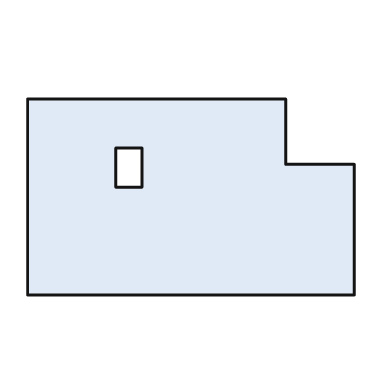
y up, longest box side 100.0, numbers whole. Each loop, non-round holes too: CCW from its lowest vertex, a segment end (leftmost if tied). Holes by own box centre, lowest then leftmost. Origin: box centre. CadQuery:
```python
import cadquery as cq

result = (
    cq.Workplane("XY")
    .moveTo(-50.0, -30.0)
    .lineTo(50.0, -30.0)
    .lineTo(50.0, 10.0)
    .lineTo(29.0, 10.0)
    .lineTo(29.0, 30.0)
    .lineTo(-50.0, 30.0)
    .close()
    .moveTo(-23.0, 3.0)
    .lineTo(-15.0, 3.0)
    .lineTo(-15.0, 15.0)
    .lineTo(-23.0, 15.0)
    .close()
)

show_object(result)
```